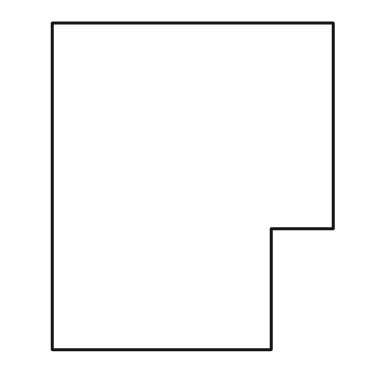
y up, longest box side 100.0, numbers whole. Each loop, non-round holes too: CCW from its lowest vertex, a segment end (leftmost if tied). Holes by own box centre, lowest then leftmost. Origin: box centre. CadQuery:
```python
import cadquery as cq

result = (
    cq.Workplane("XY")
    .moveTo(-43.0, -50.0)
    .lineTo(24.0, -50.0)
    .lineTo(24.0, -13.0)
    .lineTo(43.0, -13.0)
    .lineTo(43.0, 50.0)
    .lineTo(-43.0, 50.0)
    .close()
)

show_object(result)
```